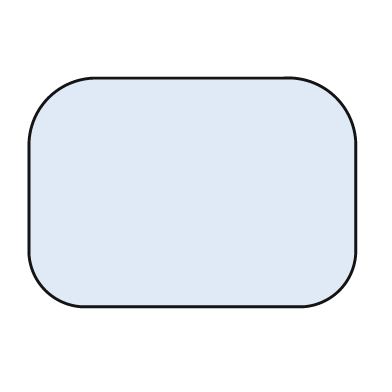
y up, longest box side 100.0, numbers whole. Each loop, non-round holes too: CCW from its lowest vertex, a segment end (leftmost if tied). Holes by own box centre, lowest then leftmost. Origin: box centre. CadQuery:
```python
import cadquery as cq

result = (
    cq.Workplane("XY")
    .moveTo(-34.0, -35.0)
    .lineTo(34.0, -35.0)
    .threePointArc((45.0, -30.0), (50.0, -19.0))
    .lineTo(50.0, 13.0)
    .threePointArc((44.0, 29.0), (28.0, 35.0))
    .lineTo(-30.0, 35.0)
    .threePointArc((-44.0, 29.0), (-50.0, 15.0))
    .lineTo(-50.0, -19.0)
    .threePointArc((-45.0, -30.0), (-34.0, -35.0))
    .close()
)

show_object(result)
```